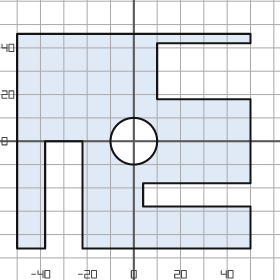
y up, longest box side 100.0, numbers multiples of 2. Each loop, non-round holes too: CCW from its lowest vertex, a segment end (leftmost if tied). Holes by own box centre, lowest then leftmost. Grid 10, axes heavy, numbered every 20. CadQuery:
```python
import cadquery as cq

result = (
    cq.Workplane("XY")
    .moveTo(-50.0, -46.0)
    .lineTo(-38.0, -46.0)
    .lineTo(-38.0, 0.0)
    .lineTo(-22.0, 0.0)
    .lineTo(-22.0, -46.0)
    .lineTo(50.0, -46.0)
    .lineTo(50.0, -28.0)
    .lineTo(4.0, -28.0)
    .lineTo(4.0, -18.0)
    .lineTo(50.0, -18.0)
    .lineTo(50.0, 18.0)
    .lineTo(10.0, 18.0)
    .lineTo(10.0, 42.0)
    .lineTo(50.0, 42.0)
    .lineTo(50.0, 46.0)
    .lineTo(-50.0, 46.0)
    .close()
    .moveTo(0.0, 0.0)
    .circle(10.0)
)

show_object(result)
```